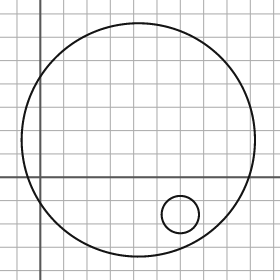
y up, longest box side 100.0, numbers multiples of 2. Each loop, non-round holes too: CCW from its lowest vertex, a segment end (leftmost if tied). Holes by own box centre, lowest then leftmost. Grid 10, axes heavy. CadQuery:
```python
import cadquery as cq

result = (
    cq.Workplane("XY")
    .moveTo(42.0, 16.0)
    .circle(50.0)
    .moveTo(60.0, -16.0)
    .circle(8.0)
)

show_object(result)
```